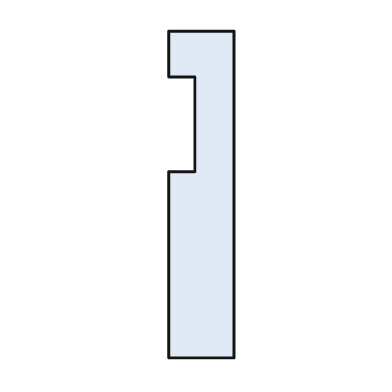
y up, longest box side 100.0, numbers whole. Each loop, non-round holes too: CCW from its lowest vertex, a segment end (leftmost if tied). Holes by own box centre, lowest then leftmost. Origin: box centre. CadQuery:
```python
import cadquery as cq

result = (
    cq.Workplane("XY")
    .moveTo(-10.0, -50.0)
    .lineTo(10.0, -50.0)
    .lineTo(10.0, 50.0)
    .lineTo(-10.0, 50.0)
    .lineTo(-10.0, 36.0)
    .lineTo(-2.0, 36.0)
    .lineTo(-2.0, 7.0)
    .lineTo(-10.0, 7.0)
    .close()
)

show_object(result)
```